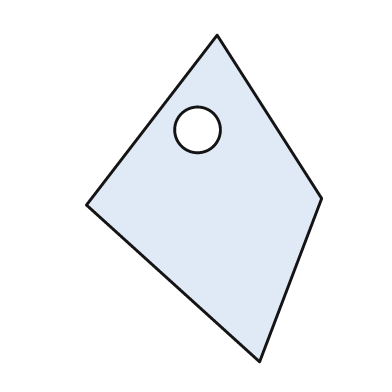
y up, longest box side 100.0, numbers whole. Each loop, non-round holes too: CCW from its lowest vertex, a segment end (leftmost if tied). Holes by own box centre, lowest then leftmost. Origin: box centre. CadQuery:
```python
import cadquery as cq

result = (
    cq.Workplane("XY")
    .moveTo(17.0, -50.0)
    .lineTo(36.0, 0.0)
    .lineTo(4.0, 50.0)
    .lineTo(-36.0, -2.0)
    .close()
    .moveTo(-2.0, 21.0)
    .circle(7.0)
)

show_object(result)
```